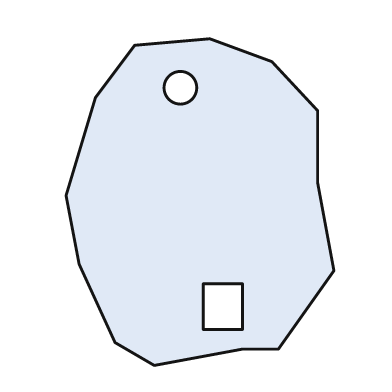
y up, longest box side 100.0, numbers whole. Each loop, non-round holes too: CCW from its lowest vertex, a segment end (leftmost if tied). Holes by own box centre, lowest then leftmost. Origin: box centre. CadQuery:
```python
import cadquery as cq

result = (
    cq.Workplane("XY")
    .moveTo(-14.0, -50.0)
    .lineTo(13.0, -45.0)
    .lineTo(24.0, -45.0)
    .lineTo(41.0, -21.0)
    .lineTo(36.0, 6.0)
    .lineTo(36.0, 28.0)
    .lineTo(22.0, 43.0)
    .lineTo(3.0, 50.0)
    .lineTo(-20.0, 48.0)
    .lineTo(-32.0, 32.0)
    .lineTo(-41.0, 2.0)
    .lineTo(-37.0, -19.0)
    .lineTo(-26.0, -43.0)
    .close()
    .moveTo(1.0, -39.0)
    .lineTo(13.0, -39.0)
    .lineTo(13.0, -25.0)
    .lineTo(1.0, -25.0)
    .close()
    .moveTo(-6.0, 35.0)
    .circle(5.0)
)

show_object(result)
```